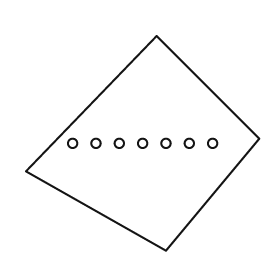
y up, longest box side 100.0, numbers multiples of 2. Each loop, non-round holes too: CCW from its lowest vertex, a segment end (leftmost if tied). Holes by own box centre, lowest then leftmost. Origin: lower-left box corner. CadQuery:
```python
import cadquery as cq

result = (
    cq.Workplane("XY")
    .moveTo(60.0, 0.0)
    .lineTo(100.0, 48.0)
    .lineTo(56.0, 92.0)
    .lineTo(0.0, 34.0)
    .close()
    .moveTo(20.0, 46.0)
    .circle(2.0)
    .moveTo(30.0, 46.0)
    .circle(2.0)
    .moveTo(40.0, 46.0)
    .circle(2.0)
    .moveTo(50.0, 46.0)
    .circle(2.0)
    .moveTo(60.0, 46.0)
    .circle(2.0)
    .moveTo(70.0, 46.0)
    .circle(2.0)
    .moveTo(80.0, 46.0)
    .circle(2.0)
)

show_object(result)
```